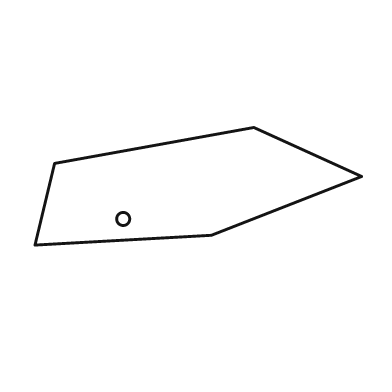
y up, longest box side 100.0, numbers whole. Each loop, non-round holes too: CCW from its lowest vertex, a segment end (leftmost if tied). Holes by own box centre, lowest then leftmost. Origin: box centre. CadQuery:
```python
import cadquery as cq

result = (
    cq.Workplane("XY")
    .moveTo(-50.0, -18.0)
    .lineTo(4.0, -15.0)
    .lineTo(50.0, 3.0)
    .lineTo(17.0, 18.0)
    .lineTo(-44.0, 7.0)
    .close()
    .moveTo(-23.0, -10.0)
    .circle(2.0)
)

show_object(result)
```